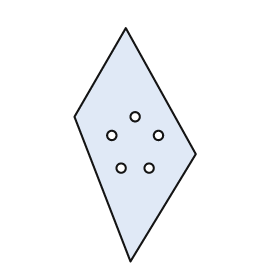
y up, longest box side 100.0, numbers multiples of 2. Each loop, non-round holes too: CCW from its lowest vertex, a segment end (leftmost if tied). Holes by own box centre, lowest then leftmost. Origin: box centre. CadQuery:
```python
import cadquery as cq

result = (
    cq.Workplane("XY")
    .moveTo(-2.0, -50.0)
    .lineTo(26.0, -4.0)
    .lineTo(-4.0, 50.0)
    .lineTo(-26.0, 12.0)
    .close()
    .moveTo(-6.0, -10.0)
    .circle(2.0)
    .moveTo(6.0, -10.0)
    .circle(2.0)
    .moveTo(-10.0, 4.0)
    .circle(2.0)
    .moveTo(10.0, 4.0)
    .circle(2.0)
    .moveTo(0.0, 12.0)
    .circle(2.0)
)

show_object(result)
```